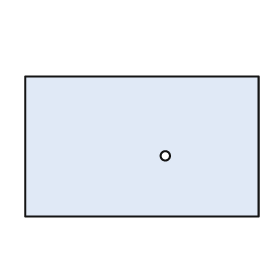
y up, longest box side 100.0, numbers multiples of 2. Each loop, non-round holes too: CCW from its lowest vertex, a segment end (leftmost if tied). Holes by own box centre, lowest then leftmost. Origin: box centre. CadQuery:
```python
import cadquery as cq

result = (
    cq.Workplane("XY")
    .moveTo(-50.0, -30.0)
    .lineTo(50.0, -30.0)
    .lineTo(50.0, 30.0)
    .lineTo(-50.0, 30.0)
    .close()
    .moveTo(10.0, -4.0)
    .circle(2.0)
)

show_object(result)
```